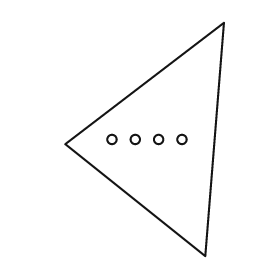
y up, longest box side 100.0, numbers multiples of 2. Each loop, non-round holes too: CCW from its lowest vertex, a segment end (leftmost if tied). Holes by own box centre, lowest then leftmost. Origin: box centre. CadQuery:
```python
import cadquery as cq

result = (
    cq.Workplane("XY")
    .moveTo(26.0, -50.0)
    .lineTo(34.0, 50.0)
    .lineTo(-34.0, -2.0)
    .close()
    .moveTo(-14.0, 0.0)
    .circle(2.0)
    .moveTo(-4.0, 0.0)
    .circle(2.0)
    .moveTo(6.0, 0.0)
    .circle(2.0)
    .moveTo(16.0, 0.0)
    .circle(2.0)
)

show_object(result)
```